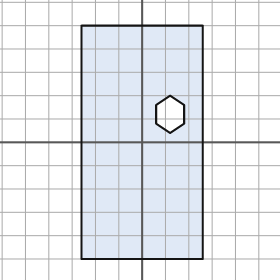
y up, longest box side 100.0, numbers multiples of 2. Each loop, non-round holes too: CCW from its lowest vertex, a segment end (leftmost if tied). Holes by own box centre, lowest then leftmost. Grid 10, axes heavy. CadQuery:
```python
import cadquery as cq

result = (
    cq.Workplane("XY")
    .moveTo(-26.0, -50.0)
    .lineTo(26.0, -50.0)
    .lineTo(26.0, 50.0)
    .lineTo(-26.0, 50.0)
    .close()
    .moveTo(12.0, 4.0)
    .lineTo(18.0, 8.0)
    .lineTo(18.0, 16.0)
    .lineTo(12.0, 20.0)
    .lineTo(6.0, 16.0)
    .lineTo(6.0, 8.0)
    .close()
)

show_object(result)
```